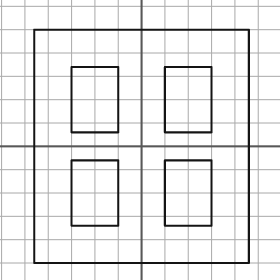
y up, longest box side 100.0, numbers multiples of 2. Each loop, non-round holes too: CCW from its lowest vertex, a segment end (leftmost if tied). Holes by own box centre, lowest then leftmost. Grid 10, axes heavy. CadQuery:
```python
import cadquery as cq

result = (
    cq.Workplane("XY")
    .moveTo(-46.0, -50.0)
    .lineTo(46.0, -50.0)
    .lineTo(46.0, 50.0)
    .lineTo(-46.0, 50.0)
    .close()
    .moveTo(-30.0, -34.0)
    .lineTo(-10.0, -34.0)
    .lineTo(-10.0, -6.0)
    .lineTo(-30.0, -6.0)
    .close()
    .moveTo(10.0, -34.0)
    .lineTo(30.0, -34.0)
    .lineTo(30.0, -6.0)
    .lineTo(10.0, -6.0)
    .close()
    .moveTo(-30.0, 6.0)
    .lineTo(-10.0, 6.0)
    .lineTo(-10.0, 34.0)
    .lineTo(-30.0, 34.0)
    .close()
    .moveTo(10.0, 6.0)
    .lineTo(30.0, 6.0)
    .lineTo(30.0, 34.0)
    .lineTo(10.0, 34.0)
    .close()
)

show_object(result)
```